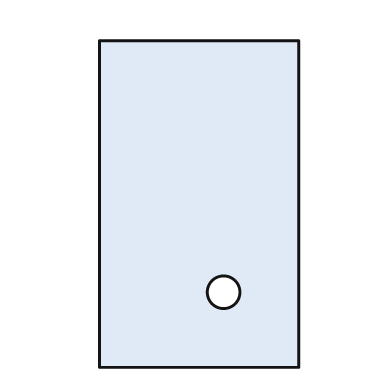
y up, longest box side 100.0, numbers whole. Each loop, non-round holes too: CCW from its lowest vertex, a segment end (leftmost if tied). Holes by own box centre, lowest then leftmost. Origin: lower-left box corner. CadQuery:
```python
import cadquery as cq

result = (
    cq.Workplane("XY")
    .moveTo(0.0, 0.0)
    .lineTo(61.0, 0.0)
    .lineTo(61.0, 100.0)
    .lineTo(0.0, 100.0)
    .close()
    .moveTo(38.0, 23.0)
    .circle(5.0)
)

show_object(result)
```